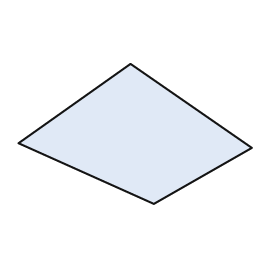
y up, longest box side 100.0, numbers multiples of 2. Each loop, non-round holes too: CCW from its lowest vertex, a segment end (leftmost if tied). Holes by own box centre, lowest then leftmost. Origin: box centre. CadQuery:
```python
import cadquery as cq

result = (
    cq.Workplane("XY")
    .moveTo(8.0, -30.0)
    .lineTo(50.0, -6.0)
    .lineTo(-2.0, 30.0)
    .lineTo(-50.0, -4.0)
    .close()
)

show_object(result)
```